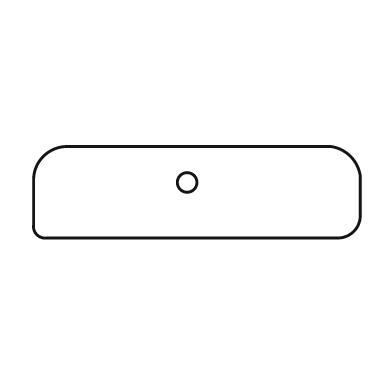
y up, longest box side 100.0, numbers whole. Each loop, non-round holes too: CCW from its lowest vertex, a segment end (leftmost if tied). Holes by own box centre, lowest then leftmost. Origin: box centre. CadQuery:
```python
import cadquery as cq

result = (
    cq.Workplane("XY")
    .moveTo(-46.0, -14.0)
    .lineTo(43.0, -14.0)
    .threePointArc((48.0, -12.0), (50.0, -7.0))
    .lineTo(50.0, 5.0)
    .threePointArc((47.0, 11.0), (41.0, 14.0))
    .lineTo(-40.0, 14.0)
    .threePointArc((-47.0, 11.0), (-50.0, 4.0))
    .lineTo(-50.0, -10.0)
    .threePointArc((-49.0, -13.0), (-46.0, -14.0))
    .close()
    .moveTo(-3.0, 3.0)
    .circle(3.0)
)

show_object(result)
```